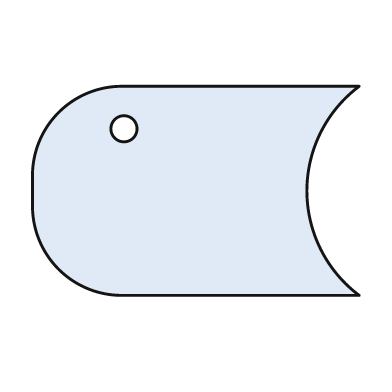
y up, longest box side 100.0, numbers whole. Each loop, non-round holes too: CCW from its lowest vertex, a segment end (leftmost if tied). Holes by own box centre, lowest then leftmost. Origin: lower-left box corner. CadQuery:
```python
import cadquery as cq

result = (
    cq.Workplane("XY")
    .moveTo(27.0, 0.0)
    .lineTo(100.0, 0.0)
    .threePointArc((84.0, 32.0), (100.0, 64.0))
    .lineTo(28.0, 64.0)
    .threePointArc((8.0, 56.0), (0.0, 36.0))
    .lineTo(0.0, 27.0)
    .threePointArc((8.0, 8.0), (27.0, 0.0))
    .close()
    .moveTo(28.0, 51.0)
    .circle(4.0)
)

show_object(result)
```